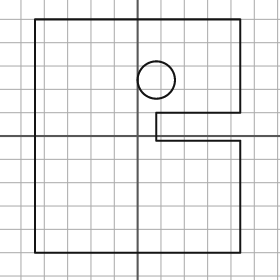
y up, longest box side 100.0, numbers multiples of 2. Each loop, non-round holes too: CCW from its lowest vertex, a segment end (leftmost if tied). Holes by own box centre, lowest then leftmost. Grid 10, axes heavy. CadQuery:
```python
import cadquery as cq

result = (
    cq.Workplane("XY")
    .moveTo(-44.0, -50.0)
    .lineTo(44.0, -50.0)
    .lineTo(44.0, -2.0)
    .lineTo(8.0, -2.0)
    .lineTo(8.0, 10.0)
    .lineTo(44.0, 10.0)
    .lineTo(44.0, 50.0)
    .lineTo(-44.0, 50.0)
    .close()
    .moveTo(8.0, 24.0)
    .circle(8.0)
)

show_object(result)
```